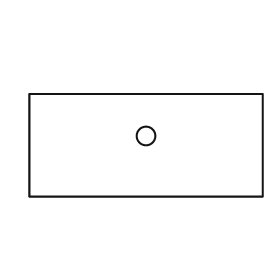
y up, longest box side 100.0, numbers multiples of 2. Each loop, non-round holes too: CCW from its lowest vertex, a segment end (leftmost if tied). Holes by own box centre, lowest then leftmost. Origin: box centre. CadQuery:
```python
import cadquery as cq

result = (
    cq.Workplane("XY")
    .moveTo(-50.0, -22.0)
    .lineTo(50.0, -22.0)
    .lineTo(50.0, 22.0)
    .lineTo(-50.0, 22.0)
    .close()
    .moveTo(0.0, 4.0)
    .circle(4.0)
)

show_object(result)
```